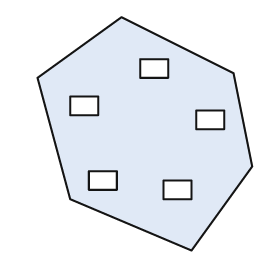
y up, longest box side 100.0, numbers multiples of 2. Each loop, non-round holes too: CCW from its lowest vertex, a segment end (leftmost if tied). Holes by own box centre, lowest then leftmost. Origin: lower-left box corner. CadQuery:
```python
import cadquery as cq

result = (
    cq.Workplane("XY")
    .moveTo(66.0, 0.0)
    .lineTo(92.0, 36.0)
    .lineTo(84.0, 76.0)
    .lineTo(36.0, 100.0)
    .lineTo(0.0, 74.0)
    .lineTo(14.0, 22.0)
    .close()
    .moveTo(54.0, 22.0)
    .lineTo(66.0, 22.0)
    .lineTo(66.0, 30.0)
    .lineTo(54.0, 30.0)
    .close()
    .moveTo(22.0, 26.0)
    .lineTo(34.0, 26.0)
    .lineTo(34.0, 34.0)
    .lineTo(22.0, 34.0)
    .close()
    .moveTo(68.0, 52.0)
    .lineTo(80.0, 52.0)
    .lineTo(80.0, 60.0)
    .lineTo(68.0, 60.0)
    .close()
    .moveTo(14.0, 58.0)
    .lineTo(26.0, 58.0)
    .lineTo(26.0, 66.0)
    .lineTo(14.0, 66.0)
    .close()
    .moveTo(44.0, 74.0)
    .lineTo(56.0, 74.0)
    .lineTo(56.0, 82.0)
    .lineTo(44.0, 82.0)
    .close()
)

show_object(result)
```